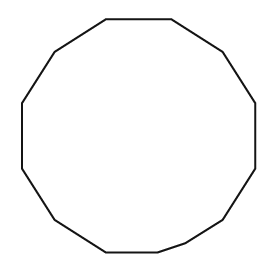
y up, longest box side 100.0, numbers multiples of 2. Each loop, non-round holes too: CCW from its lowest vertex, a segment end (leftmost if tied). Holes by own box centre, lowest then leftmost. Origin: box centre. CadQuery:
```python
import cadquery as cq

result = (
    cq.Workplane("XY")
    .moveTo(-14.0, -50.0)
    .lineTo(8.0, -50.0)
    .lineTo(20.0, -46.0)
    .lineTo(36.0, -36.0)
    .lineTo(50.0, -14.0)
    .lineTo(50.0, 14.0)
    .lineTo(36.0, 36.0)
    .lineTo(14.0, 50.0)
    .lineTo(-14.0, 50.0)
    .lineTo(-36.0, 36.0)
    .lineTo(-50.0, 14.0)
    .lineTo(-50.0, -14.0)
    .lineTo(-36.0, -36.0)
    .close()
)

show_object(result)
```